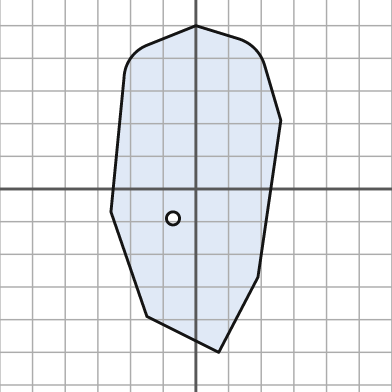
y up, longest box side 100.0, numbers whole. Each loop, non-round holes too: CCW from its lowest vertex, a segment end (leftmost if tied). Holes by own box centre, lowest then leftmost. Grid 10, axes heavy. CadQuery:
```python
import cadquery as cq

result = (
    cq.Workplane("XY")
    .moveTo(7.0, -50.0)
    .lineTo(19.0, -27.0)
    .lineTo(26.0, 21.0)
    .lineTo(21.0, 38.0)
    .threePointArc((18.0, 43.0), (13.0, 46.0))
    .lineTo(0.0, 50.0)
    .lineTo(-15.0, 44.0)
    .threePointArc((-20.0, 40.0), (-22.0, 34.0))
    .lineTo(-26.0, -7.0)
    .lineTo(-15.0, -39.0)
    .close()
    .moveTo(-7.0, -9.0)
    .circle(2.0)
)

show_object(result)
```